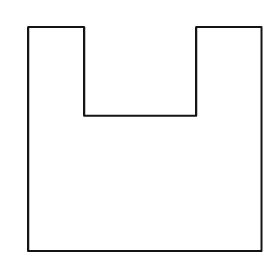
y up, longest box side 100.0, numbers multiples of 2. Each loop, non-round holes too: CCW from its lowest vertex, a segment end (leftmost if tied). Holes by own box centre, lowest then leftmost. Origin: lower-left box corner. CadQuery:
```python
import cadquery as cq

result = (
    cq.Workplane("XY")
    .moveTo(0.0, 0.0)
    .lineTo(100.0, 0.0)
    .lineTo(100.0, 96.0)
    .lineTo(72.0, 96.0)
    .lineTo(72.0, 58.0)
    .lineTo(24.0, 58.0)
    .lineTo(24.0, 96.0)
    .lineTo(0.0, 96.0)
    .close()
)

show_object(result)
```